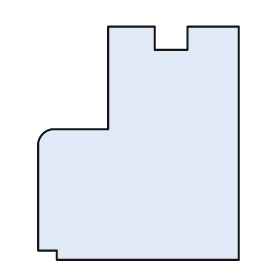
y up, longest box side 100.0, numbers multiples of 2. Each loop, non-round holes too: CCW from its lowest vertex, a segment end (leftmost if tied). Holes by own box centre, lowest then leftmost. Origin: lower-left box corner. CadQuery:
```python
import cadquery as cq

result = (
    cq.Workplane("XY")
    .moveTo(8.0, 0.0)
    .lineTo(86.0, 0.0)
    .lineTo(86.0, 100.0)
    .lineTo(64.0, 100.0)
    .lineTo(64.0, 90.0)
    .lineTo(50.0, 90.0)
    .lineTo(50.0, 100.0)
    .lineTo(30.0, 100.0)
    .lineTo(30.0, 56.0)
    .lineTo(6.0, 56.0)
    .threePointArc((2.0, 54.0), (0.0, 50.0))
    .lineTo(0.0, 4.0)
    .lineTo(8.0, 4.0)
    .close()
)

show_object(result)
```